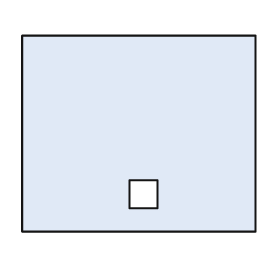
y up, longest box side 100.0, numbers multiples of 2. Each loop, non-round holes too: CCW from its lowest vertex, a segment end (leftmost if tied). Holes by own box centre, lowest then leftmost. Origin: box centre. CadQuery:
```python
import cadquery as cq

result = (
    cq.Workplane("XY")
    .moveTo(-50.0, -42.0)
    .lineTo(50.0, -42.0)
    .lineTo(50.0, 42.0)
    .lineTo(-50.0, 42.0)
    .close()
    .moveTo(-4.0, -32.0)
    .lineTo(8.0, -32.0)
    .lineTo(8.0, -20.0)
    .lineTo(-4.0, -20.0)
    .close()
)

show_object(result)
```